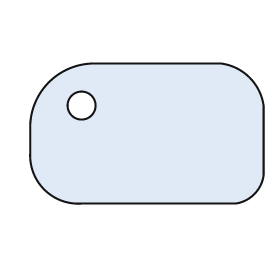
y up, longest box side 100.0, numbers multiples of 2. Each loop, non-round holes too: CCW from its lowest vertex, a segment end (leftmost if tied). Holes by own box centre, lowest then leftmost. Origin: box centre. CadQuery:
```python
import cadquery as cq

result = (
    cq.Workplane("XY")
    .moveTo(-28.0, -30.0)
    .lineTo(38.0, -30.0)
    .threePointArc((46.0, -26.0), (50.0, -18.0))
    .lineTo(50.0, 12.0)
    .threePointArc((44.0, 24.0), (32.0, 30.0))
    .lineTo(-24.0, 30.0)
    .threePointArc((-42.0, 22.0), (-50.0, 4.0))
    .lineTo(-50.0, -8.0)
    .threePointArc((-44.0, -24.0), (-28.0, -30.0))
    .close()
    .moveTo(-28.0, 12.0)
    .circle(6.0)
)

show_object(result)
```